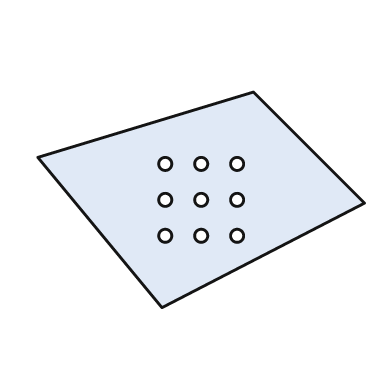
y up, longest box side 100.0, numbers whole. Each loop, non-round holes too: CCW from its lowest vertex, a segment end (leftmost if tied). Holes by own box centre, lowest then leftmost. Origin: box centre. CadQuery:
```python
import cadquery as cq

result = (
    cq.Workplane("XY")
    .moveTo(-12.0, -33.0)
    .lineTo(50.0, -1.0)
    .lineTo(16.0, 33.0)
    .lineTo(-50.0, 13.0)
    .close()
    .moveTo(-11.0, -11.0)
    .circle(2.0)
    .moveTo(0.0, -11.0)
    .circle(2.0)
    .moveTo(11.0, -11.0)
    .circle(2.0)
    .moveTo(-11.0, 0.0)
    .circle(2.0)
    .moveTo(0.0, 0.0)
    .circle(2.0)
    .moveTo(11.0, 0.0)
    .circle(2.0)
    .moveTo(-11.0, 11.0)
    .circle(2.0)
    .moveTo(0.0, 11.0)
    .circle(2.0)
    .moveTo(11.0, 11.0)
    .circle(2.0)
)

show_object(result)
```